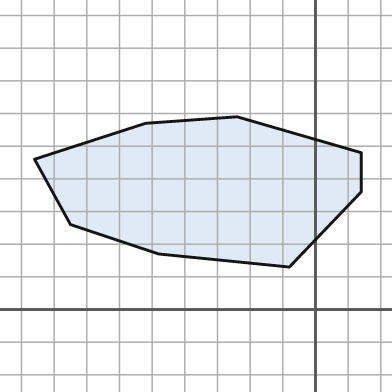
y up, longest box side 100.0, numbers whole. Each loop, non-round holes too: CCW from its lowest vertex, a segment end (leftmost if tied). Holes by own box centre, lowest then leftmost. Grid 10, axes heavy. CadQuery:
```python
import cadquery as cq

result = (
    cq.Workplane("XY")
    .moveTo(-8.0, 13.0)
    .lineTo(14.0, 36.0)
    .lineTo(14.0, 48.0)
    .lineTo(-24.0, 59.0)
    .lineTo(-52.0, 57.0)
    .lineTo(-86.0, 46.0)
    .lineTo(-75.0, 26.0)
    .lineTo(-48.0, 17.0)
    .close()
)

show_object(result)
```